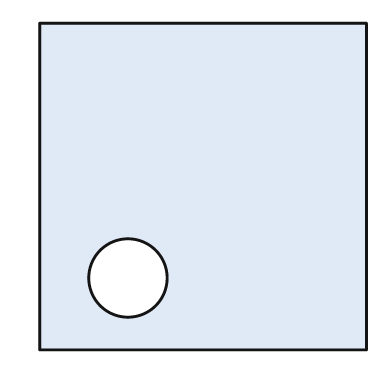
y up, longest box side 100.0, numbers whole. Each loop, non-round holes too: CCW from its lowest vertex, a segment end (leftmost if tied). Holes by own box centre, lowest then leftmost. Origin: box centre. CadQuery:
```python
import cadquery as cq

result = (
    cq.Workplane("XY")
    .moveTo(-50.0, -50.0)
    .lineTo(50.0, -50.0)
    .lineTo(50.0, 50.0)
    .lineTo(-50.0, 50.0)
    .close()
    .moveTo(-23.0, -28.0)
    .circle(12.0)
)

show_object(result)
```